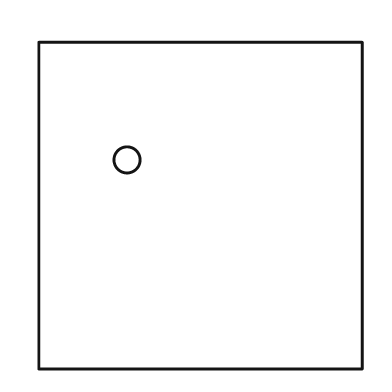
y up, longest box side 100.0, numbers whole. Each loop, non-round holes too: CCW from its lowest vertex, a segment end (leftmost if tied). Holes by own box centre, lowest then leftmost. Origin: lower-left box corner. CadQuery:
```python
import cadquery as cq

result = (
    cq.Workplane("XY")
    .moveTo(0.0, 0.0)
    .lineTo(99.0, 0.0)
    .lineTo(99.0, 100.0)
    .lineTo(0.0, 100.0)
    .close()
    .moveTo(27.0, 64.0)
    .circle(4.0)
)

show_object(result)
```